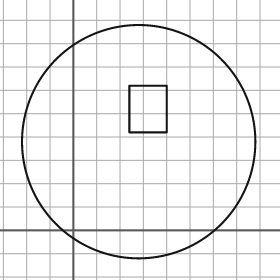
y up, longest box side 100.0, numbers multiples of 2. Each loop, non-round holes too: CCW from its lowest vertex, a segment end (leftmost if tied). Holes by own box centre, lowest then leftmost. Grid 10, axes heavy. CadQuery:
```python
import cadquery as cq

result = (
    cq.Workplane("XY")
    .moveTo(28.0, 38.0)
    .circle(50.0)
    .moveTo(24.0, 42.0)
    .lineTo(40.0, 42.0)
    .lineTo(40.0, 62.0)
    .lineTo(24.0, 62.0)
    .close()
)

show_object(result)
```